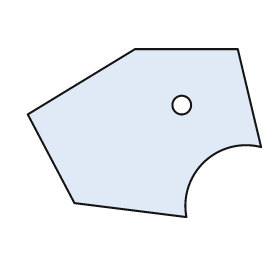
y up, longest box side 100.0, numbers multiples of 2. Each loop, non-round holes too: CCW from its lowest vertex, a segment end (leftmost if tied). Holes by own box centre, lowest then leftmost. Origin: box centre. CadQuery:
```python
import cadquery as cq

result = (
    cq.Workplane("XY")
    .moveTo(18.0, -36.0)
    .threePointArc((26.0, -12.0), (50.0, -6.0))
    .lineTo(40.0, 36.0)
    .lineTo(-4.0, 36.0)
    .lineTo(-50.0, 8.0)
    .lineTo(-30.0, -30.0)
    .close()
    .moveTo(16.0, 12.0)
    .circle(4.0)
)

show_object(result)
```